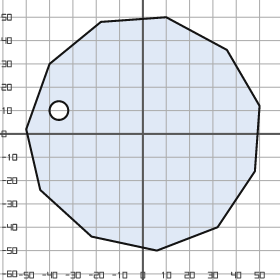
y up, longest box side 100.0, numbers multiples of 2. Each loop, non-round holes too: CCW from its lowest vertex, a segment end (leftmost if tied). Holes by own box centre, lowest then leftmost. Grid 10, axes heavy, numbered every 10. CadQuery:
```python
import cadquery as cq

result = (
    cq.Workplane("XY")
    .moveTo(6.0, -50.0)
    .lineTo(32.0, -40.0)
    .lineTo(48.0, -16.0)
    .lineTo(50.0, 12.0)
    .lineTo(36.0, 36.0)
    .lineTo(10.0, 50.0)
    .lineTo(-18.0, 48.0)
    .lineTo(-40.0, 30.0)
    .lineTo(-50.0, 2.0)
    .lineTo(-44.0, -24.0)
    .lineTo(-22.0, -44.0)
    .close()
    .moveTo(-36.0, 10.0)
    .circle(4.0)
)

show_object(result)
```